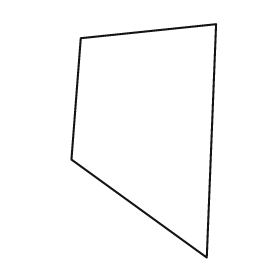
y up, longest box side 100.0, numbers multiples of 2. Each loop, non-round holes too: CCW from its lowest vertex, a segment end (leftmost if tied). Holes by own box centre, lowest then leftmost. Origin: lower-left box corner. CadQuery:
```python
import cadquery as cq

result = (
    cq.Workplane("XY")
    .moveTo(58.0, 0.0)
    .lineTo(62.0, 100.0)
    .lineTo(4.0, 94.0)
    .lineTo(0.0, 42.0)
    .close()
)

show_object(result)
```